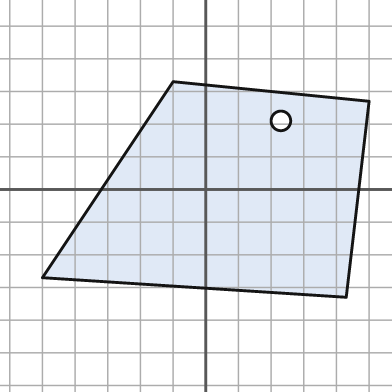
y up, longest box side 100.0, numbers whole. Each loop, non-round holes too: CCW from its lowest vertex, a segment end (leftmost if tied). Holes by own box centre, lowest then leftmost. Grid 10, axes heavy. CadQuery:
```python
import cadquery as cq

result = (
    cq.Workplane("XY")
    .moveTo(43.0, -33.0)
    .lineTo(50.0, 27.0)
    .lineTo(-10.0, 33.0)
    .lineTo(-50.0, -27.0)
    .close()
    .moveTo(23.0, 21.0)
    .circle(3.0)
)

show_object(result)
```